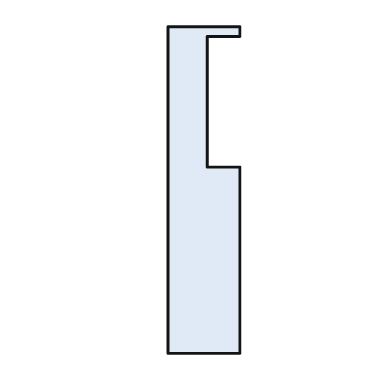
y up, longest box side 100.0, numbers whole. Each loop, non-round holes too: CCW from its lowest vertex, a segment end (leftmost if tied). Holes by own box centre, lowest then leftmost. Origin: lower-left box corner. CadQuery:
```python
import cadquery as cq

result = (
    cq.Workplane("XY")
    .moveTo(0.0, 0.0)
    .lineTo(22.0, 0.0)
    .lineTo(22.0, 57.0)
    .lineTo(12.0, 57.0)
    .lineTo(12.0, 97.0)
    .lineTo(22.0, 97.0)
    .lineTo(22.0, 100.0)
    .lineTo(0.0, 100.0)
    .close()
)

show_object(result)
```